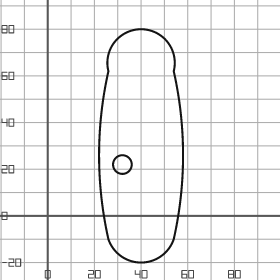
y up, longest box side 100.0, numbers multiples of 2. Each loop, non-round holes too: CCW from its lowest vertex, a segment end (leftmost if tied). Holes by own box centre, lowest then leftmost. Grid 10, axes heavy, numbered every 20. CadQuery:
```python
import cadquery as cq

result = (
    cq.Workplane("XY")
    .moveTo(26.0, -10.0)
    .threePointArc((40.0, -20.0), (54.0, -10.0))
    .threePointArc((58.0, 26.0), (54.0, 62.0))
    .threePointArc((40.0, 80.0), (26.0, 62.0))
    .threePointArc((22.0, 26.0), (26.0, -10.0))
    .close()
    .moveTo(32.0, 22.0)
    .circle(4.0)
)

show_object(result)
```